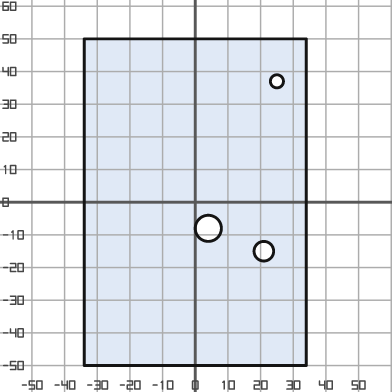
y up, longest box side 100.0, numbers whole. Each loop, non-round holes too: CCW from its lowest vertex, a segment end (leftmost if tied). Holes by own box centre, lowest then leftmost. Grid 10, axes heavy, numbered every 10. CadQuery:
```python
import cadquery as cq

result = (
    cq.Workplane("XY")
    .moveTo(-34.0, -50.0)
    .lineTo(34.0, -50.0)
    .lineTo(34.0, 50.0)
    .lineTo(-34.0, 50.0)
    .close()
    .moveTo(21.0, -15.0)
    .circle(3.0)
    .moveTo(4.0, -8.0)
    .circle(4.0)
    .moveTo(25.0, 37.0)
    .circle(2.0)
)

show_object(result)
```